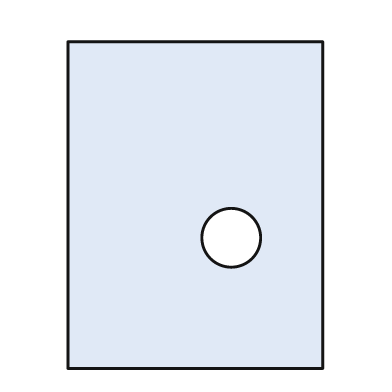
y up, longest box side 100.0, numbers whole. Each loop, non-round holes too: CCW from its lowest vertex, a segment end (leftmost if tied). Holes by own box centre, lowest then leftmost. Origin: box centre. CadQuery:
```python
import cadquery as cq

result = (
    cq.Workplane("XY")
    .moveTo(-39.0, -50.0)
    .lineTo(39.0, -50.0)
    .lineTo(39.0, 50.0)
    .lineTo(-39.0, 50.0)
    .close()
    .moveTo(11.0, -10.0)
    .circle(9.0)
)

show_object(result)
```